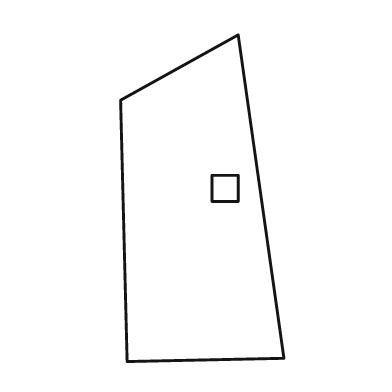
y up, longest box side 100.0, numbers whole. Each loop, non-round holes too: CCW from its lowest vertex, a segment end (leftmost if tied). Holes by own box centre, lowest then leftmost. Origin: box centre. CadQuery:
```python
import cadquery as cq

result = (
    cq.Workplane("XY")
    .moveTo(-23.0, -50.0)
    .lineTo(25.0, -49.0)
    .lineTo(11.0, 50.0)
    .lineTo(-25.0, 30.0)
    .close()
    .moveTo(3.0, -1.0)
    .lineTo(11.0, -1.0)
    .lineTo(11.0, 7.0)
    .lineTo(3.0, 7.0)
    .close()
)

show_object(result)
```